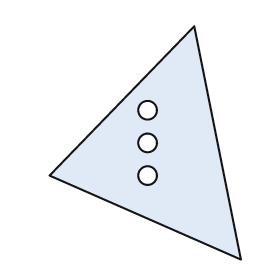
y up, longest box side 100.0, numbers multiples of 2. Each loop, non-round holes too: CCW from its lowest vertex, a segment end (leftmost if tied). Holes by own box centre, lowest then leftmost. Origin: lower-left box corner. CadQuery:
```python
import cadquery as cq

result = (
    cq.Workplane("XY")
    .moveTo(82.0, 0.0)
    .lineTo(62.0, 100.0)
    .lineTo(0.0, 36.0)
    .close()
    .moveTo(42.0, 36.0)
    .circle(4.0)
    .moveTo(42.0, 50.0)
    .circle(4.0)
    .moveTo(42.0, 64.0)
    .circle(4.0)
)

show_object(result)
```